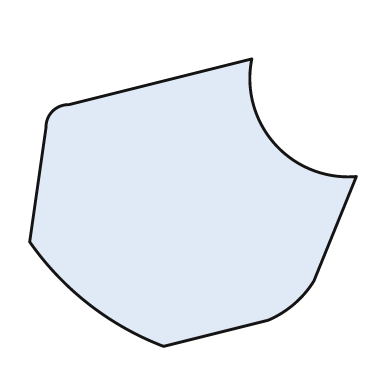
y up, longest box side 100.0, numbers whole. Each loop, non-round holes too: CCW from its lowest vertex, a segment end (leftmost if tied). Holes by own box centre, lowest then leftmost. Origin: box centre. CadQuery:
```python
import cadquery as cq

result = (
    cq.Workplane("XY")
    .moveTo(-9.0, -44.0)
    .lineTo(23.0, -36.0)
    .threePointArc((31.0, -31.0), (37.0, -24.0))
    .lineTo(50.0, 8.0)
    .threePointArc((25.0, 18.0), (18.0, 44.0))
    .lineTo(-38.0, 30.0)
    .threePointArc((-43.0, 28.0), (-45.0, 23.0))
    .lineTo(-50.0, -12.0)
    .threePointArc((-32.0, -31.0), (-9.0, -44.0))
    .close()
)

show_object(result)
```